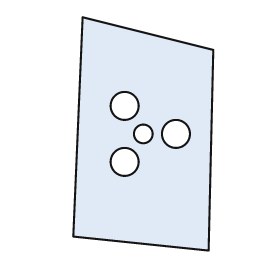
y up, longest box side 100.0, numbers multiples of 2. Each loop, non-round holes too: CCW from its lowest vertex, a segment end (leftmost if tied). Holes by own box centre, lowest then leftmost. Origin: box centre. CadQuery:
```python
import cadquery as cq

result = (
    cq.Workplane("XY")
    .moveTo(28.0, -50.0)
    .lineTo(30.0, 36.0)
    .lineTo(-26.0, 50.0)
    .lineTo(-30.0, -44.0)
    .close()
    .moveTo(-8.0, -12.0)
    .circle(6.0)
    .moveTo(0.0, 0.0)
    .circle(4.0)
    .moveTo(14.0, 0.0)
    .circle(6.0)
    .moveTo(-8.0, 12.0)
    .circle(6.0)
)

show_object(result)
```